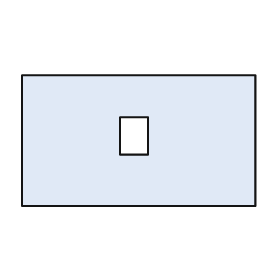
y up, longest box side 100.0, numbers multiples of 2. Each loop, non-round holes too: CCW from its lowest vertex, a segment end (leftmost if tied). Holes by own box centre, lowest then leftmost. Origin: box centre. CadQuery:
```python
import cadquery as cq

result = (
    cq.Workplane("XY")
    .moveTo(-50.0, -28.0)
    .lineTo(50.0, -28.0)
    .lineTo(50.0, 28.0)
    .lineTo(-50.0, 28.0)
    .close()
    .moveTo(-8.0, -6.0)
    .lineTo(4.0, -6.0)
    .lineTo(4.0, 10.0)
    .lineTo(-8.0, 10.0)
    .close()
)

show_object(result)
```